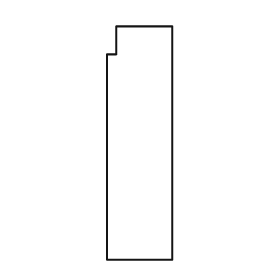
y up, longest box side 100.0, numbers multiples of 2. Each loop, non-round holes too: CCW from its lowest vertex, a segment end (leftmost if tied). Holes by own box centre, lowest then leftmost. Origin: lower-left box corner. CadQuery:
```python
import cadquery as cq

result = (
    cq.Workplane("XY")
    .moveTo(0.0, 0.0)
    .lineTo(28.0, 0.0)
    .lineTo(28.0, 100.0)
    .lineTo(4.0, 100.0)
    .lineTo(4.0, 88.0)
    .lineTo(0.0, 88.0)
    .close()
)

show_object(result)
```